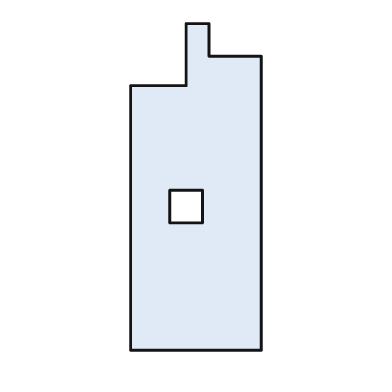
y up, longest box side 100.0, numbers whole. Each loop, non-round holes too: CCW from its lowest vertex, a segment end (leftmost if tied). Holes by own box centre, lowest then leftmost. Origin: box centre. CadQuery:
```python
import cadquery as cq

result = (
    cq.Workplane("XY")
    .moveTo(-20.0, -50.0)
    .lineTo(20.0, -50.0)
    .lineTo(20.0, 40.0)
    .lineTo(4.0, 40.0)
    .lineTo(4.0, 50.0)
    .lineTo(-3.0, 50.0)
    .lineTo(-3.0, 31.0)
    .lineTo(-20.0, 31.0)
    .close()
    .moveTo(-8.0, -11.0)
    .lineTo(2.0, -11.0)
    .lineTo(2.0, -1.0)
    .lineTo(-8.0, -1.0)
    .close()
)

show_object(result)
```